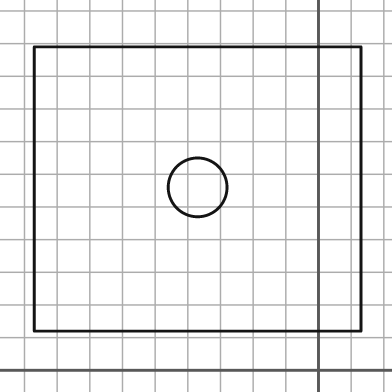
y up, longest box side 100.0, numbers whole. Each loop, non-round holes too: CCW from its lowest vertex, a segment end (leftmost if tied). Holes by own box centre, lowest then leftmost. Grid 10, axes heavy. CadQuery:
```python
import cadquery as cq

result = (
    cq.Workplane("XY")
    .moveTo(-87.0, 12.0)
    .lineTo(13.0, 12.0)
    .lineTo(13.0, 99.0)
    .lineTo(-87.0, 99.0)
    .close()
    .moveTo(-37.0, 56.0)
    .circle(9.0)
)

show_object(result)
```